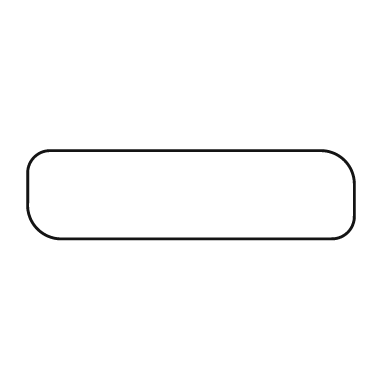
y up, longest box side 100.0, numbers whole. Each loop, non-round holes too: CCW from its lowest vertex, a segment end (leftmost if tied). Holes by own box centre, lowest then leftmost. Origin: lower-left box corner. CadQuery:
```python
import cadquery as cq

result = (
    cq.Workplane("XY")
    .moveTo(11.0, 0.0)
    .lineTo(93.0, 0.0)
    .threePointArc((98.0, 2.0), (100.0, 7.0))
    .lineTo(100.0, 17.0)
    .threePointArc((97.0, 24.0), (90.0, 27.0))
    .lineTo(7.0, 27.0)
    .threePointArc((2.0, 25.0), (0.0, 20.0))
    .lineTo(0.0, 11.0)
    .threePointArc((3.0, 3.0), (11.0, 0.0))
    .close()
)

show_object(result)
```